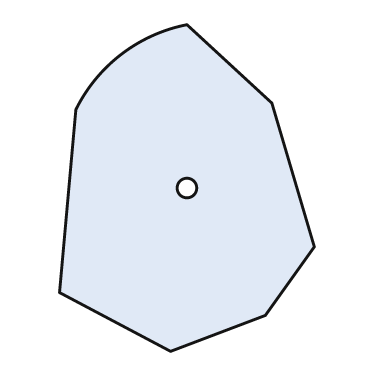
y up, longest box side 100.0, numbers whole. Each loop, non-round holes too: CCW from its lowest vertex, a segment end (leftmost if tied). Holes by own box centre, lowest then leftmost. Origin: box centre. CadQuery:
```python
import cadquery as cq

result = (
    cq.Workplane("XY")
    .moveTo(-5.0, -50.0)
    .lineTo(24.0, -39.0)
    .lineTo(39.0, -18.0)
    .lineTo(26.0, 26.0)
    .lineTo(0.0, 50.0)
    .threePointArc((-20.0, 41.0), (-34.0, 24.0))
    .lineTo(-39.0, -32.0)
    .close()
    .moveTo(0.0, 0.0)
    .circle(3.0)
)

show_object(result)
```